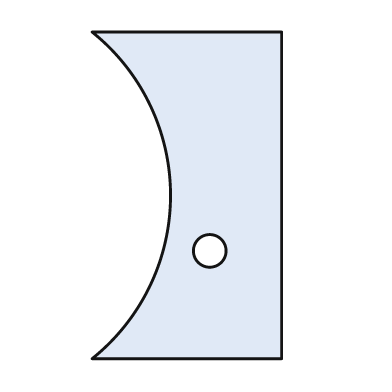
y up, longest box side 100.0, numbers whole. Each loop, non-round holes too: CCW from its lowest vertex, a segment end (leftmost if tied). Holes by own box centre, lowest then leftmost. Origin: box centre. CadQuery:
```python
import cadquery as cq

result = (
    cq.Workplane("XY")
    .moveTo(-29.0, -50.0)
    .lineTo(29.0, -50.0)
    .lineTo(29.0, 50.0)
    .lineTo(-29.0, 50.0)
    .threePointArc((-5.0, 0.0), (-29.0, -50.0))
    .close()
    .moveTo(7.0, -17.0)
    .circle(5.0)
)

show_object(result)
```